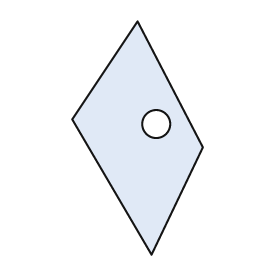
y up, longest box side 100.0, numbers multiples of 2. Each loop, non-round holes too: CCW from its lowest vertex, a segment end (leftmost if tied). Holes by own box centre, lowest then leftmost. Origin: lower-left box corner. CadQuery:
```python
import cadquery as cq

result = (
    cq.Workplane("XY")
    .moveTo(34.0, 0.0)
    .lineTo(56.0, 46.0)
    .lineTo(28.0, 100.0)
    .lineTo(0.0, 58.0)
    .close()
    .moveTo(36.0, 56.0)
    .circle(6.0)
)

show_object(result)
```